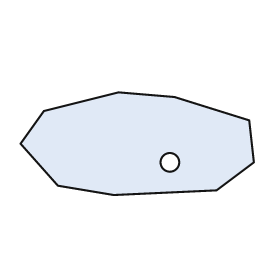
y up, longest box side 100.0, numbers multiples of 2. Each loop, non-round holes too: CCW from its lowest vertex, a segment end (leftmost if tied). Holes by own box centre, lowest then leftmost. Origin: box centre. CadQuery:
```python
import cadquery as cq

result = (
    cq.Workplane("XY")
    .moveTo(-10.0, -22.0)
    .lineTo(34.0, -20.0)
    .lineTo(50.0, -8.0)
    .lineTo(48.0, 10.0)
    .lineTo(16.0, 20.0)
    .lineTo(-8.0, 22.0)
    .lineTo(-40.0, 14.0)
    .lineTo(-50.0, 0.0)
    .lineTo(-34.0, -18.0)
    .close()
    .moveTo(14.0, -8.0)
    .circle(4.0)
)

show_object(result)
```